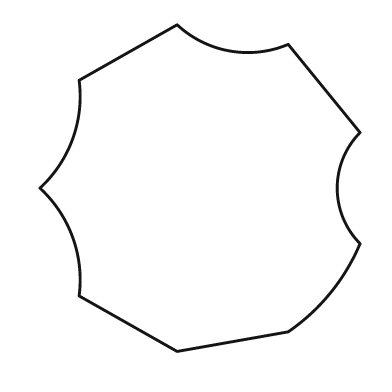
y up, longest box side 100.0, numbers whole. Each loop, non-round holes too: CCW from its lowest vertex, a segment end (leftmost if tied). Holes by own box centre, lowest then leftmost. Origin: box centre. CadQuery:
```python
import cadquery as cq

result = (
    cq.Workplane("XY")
    .moveTo(-7.0, -50.0)
    .lineTo(27.0, -44.0)
    .threePointArc((40.0, -32.0), (49.0, -17.0))
    .threePointArc((42.0, 0.0), (49.0, 17.0))
    .lineTo(27.0, 44.0)
    .threePointArc((9.0, 42.0), (-7.0, 50.0))
    .lineTo(-37.0, 33.0)
    .threePointArc((-39.0, 15.0), (-49.0, 0.0))
    .threePointArc((-39.0, -15.0), (-37.0, -33.0))
    .close()
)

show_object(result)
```